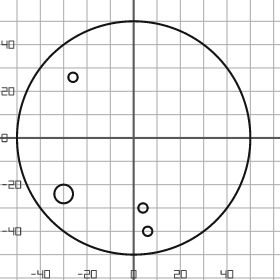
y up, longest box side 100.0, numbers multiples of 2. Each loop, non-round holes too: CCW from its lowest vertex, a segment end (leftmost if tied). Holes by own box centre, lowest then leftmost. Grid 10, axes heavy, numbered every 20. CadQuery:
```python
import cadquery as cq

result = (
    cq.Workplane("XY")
    .moveTo(0.0, 0.0)
    .circle(50.0)
    .moveTo(6.0, -40.0)
    .circle(2.0)
    .moveTo(4.0, -30.0)
    .circle(2.0)
    .moveTo(-30.0, -24.0)
    .circle(4.0)
    .moveTo(-26.0, 26.0)
    .circle(2.0)
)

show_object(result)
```